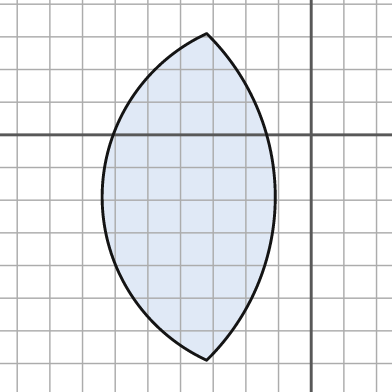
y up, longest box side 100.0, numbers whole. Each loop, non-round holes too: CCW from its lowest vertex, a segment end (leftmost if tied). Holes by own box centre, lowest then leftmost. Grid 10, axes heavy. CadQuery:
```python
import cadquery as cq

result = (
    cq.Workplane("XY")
    .moveTo(-32.0, -69.0)
    .threePointArc((-11.0, -19.0), (-32.0, 31.0))
    .threePointArc((-64.0, -19.0), (-32.0, -69.0))
    .close()
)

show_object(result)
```